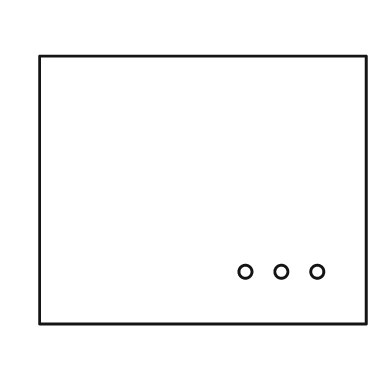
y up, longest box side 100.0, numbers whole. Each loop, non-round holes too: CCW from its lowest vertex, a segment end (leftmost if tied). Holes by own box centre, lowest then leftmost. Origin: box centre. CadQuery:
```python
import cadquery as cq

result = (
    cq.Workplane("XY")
    .moveTo(-50.0, -41.0)
    .lineTo(50.0, -41.0)
    .lineTo(50.0, 41.0)
    .lineTo(-50.0, 41.0)
    .close()
    .moveTo(13.0, -25.0)
    .circle(2.0)
    .moveTo(24.0, -25.0)
    .circle(2.0)
    .moveTo(35.0, -25.0)
    .circle(2.0)
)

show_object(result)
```